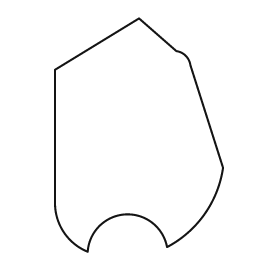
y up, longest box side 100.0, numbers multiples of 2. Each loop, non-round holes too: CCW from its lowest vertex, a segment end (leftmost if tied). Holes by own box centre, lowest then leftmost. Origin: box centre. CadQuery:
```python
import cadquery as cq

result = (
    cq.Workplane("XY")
    .moveTo(-22.0, -50.0)
    .threePointArc((-6.0, -34.0), (12.0, -48.0))
    .threePointArc((28.0, -34.0), (36.0, -14.0))
    .lineTo(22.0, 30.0)
    .threePointArc((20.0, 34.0), (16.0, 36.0))
    .lineTo(0.0, 50.0)
    .lineTo(-36.0, 28.0)
    .lineTo(-36.0, -30.0)
    .threePointArc((-32.0, -42.0), (-22.0, -50.0))
    .close()
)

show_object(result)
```